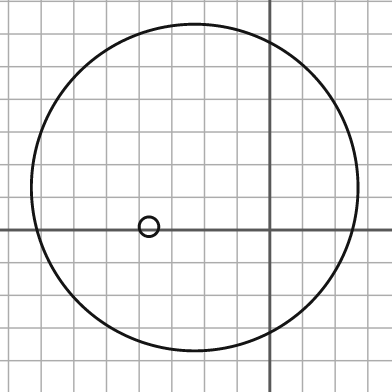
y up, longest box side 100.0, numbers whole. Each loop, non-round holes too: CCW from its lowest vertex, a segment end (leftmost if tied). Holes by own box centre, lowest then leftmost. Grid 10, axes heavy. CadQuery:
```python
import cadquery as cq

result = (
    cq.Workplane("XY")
    .moveTo(-23.0, 13.0)
    .circle(50.0)
    .moveTo(-37.0, 1.0)
    .circle(3.0)
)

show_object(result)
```